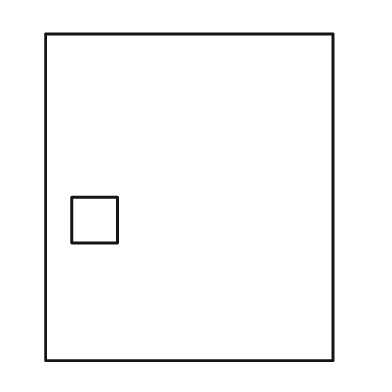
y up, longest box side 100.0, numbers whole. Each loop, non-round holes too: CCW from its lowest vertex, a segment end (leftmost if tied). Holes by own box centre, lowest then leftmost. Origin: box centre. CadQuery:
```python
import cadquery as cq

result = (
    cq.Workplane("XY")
    .moveTo(-44.0, -50.0)
    .lineTo(44.0, -50.0)
    .lineTo(44.0, 50.0)
    .lineTo(-44.0, 50.0)
    .close()
    .moveTo(-36.0, -14.0)
    .lineTo(-22.0, -14.0)
    .lineTo(-22.0, 0.0)
    .lineTo(-36.0, 0.0)
    .close()
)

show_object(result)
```